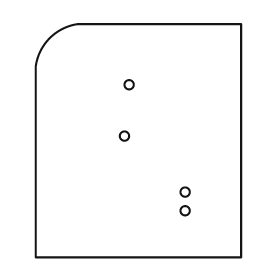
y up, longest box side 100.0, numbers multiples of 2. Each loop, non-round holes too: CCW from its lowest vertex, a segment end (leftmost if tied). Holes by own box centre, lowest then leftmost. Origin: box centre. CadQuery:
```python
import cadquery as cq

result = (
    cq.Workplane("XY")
    .moveTo(-44.0, -50.0)
    .lineTo(44.0, -50.0)
    .lineTo(44.0, 50.0)
    .lineTo(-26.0, 50.0)
    .threePointArc((-38.0, 44.0), (-44.0, 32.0))
    .close()
    .moveTo(20.0, -30.0)
    .circle(2.0)
    .moveTo(20.0, -22.0)
    .circle(2.0)
    .moveTo(-6.0, 2.0)
    .circle(2.0)
    .moveTo(-4.0, 24.0)
    .circle(2.0)
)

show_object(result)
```